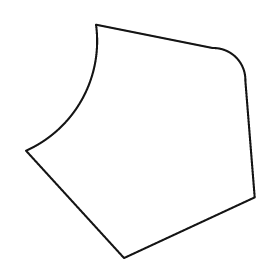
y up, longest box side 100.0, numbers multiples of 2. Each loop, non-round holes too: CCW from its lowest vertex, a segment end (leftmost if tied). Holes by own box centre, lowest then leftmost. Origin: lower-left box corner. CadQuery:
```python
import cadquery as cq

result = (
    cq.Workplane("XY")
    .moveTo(42.0, 0.0)
    .lineTo(98.0, 26.0)
    .lineTo(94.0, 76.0)
    .threePointArc((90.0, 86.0), (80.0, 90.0))
    .lineTo(30.0, 100.0)
    .threePointArc((24.0, 68.0), (0.0, 46.0))
    .close()
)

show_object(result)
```